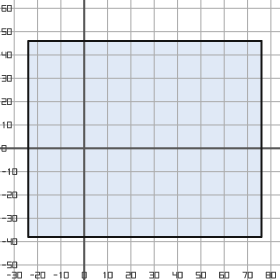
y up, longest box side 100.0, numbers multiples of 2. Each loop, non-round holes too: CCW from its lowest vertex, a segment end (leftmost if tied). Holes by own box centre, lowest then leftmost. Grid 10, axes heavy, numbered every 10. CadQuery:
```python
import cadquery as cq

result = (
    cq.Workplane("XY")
    .moveTo(-24.0, -38.0)
    .lineTo(76.0, -38.0)
    .lineTo(76.0, 46.0)
    .lineTo(-24.0, 46.0)
    .close()
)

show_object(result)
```